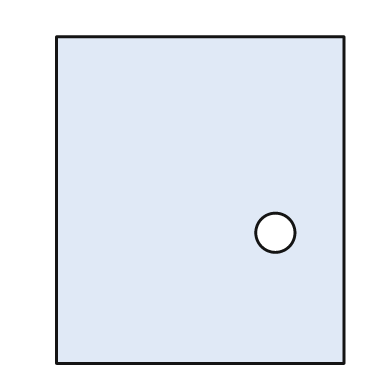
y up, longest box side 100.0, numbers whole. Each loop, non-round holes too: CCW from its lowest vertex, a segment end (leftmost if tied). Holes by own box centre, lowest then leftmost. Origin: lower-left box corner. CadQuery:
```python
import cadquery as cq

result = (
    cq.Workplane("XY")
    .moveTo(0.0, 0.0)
    .lineTo(88.0, 0.0)
    .lineTo(88.0, 100.0)
    .lineTo(0.0, 100.0)
    .close()
    .moveTo(67.0, 40.0)
    .circle(6.0)
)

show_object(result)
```